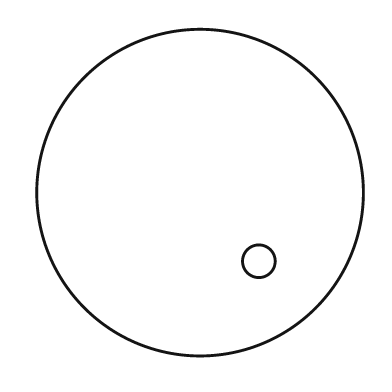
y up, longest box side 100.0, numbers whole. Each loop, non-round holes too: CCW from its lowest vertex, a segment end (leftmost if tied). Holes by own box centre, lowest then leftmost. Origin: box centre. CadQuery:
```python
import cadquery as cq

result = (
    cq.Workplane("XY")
    .moveTo(0.0, 0.0)
    .circle(50.0)
    .moveTo(18.0, -21.0)
    .circle(5.0)
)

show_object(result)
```